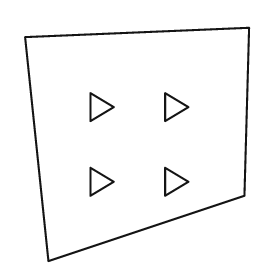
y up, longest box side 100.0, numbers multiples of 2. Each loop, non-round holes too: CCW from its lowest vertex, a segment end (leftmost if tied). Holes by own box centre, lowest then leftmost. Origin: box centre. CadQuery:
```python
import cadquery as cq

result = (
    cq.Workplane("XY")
    .moveTo(-38.0, -50.0)
    .lineTo(46.0, -22.0)
    .lineTo(48.0, 50.0)
    .lineTo(-48.0, 46.0)
    .close()
    .moveTo(-20.0, -22.0)
    .lineTo(-10.0, -16.0)
    .lineTo(-20.0, -10.0)
    .close()
    .moveTo(12.0, -22.0)
    .lineTo(22.0, -16.0)
    .lineTo(12.0, -10.0)
    .close()
    .moveTo(-20.0, 10.0)
    .lineTo(-10.0, 16.0)
    .lineTo(-20.0, 22.0)
    .close()
    .moveTo(12.0, 10.0)
    .lineTo(22.0, 16.0)
    .lineTo(12.0, 22.0)
    .close()
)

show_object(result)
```